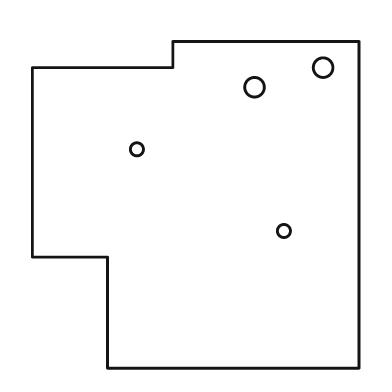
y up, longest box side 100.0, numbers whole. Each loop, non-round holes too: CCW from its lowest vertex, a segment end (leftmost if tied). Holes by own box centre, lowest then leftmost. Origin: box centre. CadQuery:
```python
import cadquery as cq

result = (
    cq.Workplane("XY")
    .moveTo(-27.0, -50.0)
    .lineTo(50.0, -50.0)
    .lineTo(50.0, 50.0)
    .lineTo(-7.0, 50.0)
    .lineTo(-7.0, 42.0)
    .lineTo(-50.0, 42.0)
    .lineTo(-50.0, -16.0)
    .lineTo(-27.0, -16.0)
    .close()
    .moveTo(27.0, -8.0)
    .circle(2.0)
    .moveTo(-18.0, 17.0)
    .circle(2.0)
    .moveTo(18.0, 36.0)
    .circle(3.0)
    .moveTo(39.0, 42.0)
    .circle(3.0)
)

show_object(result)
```